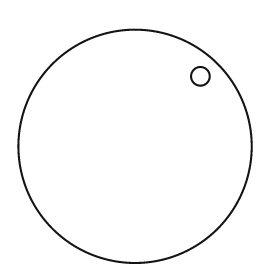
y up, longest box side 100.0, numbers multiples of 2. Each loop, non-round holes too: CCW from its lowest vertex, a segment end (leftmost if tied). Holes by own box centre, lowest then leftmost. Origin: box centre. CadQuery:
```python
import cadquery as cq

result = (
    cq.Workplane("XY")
    .moveTo(0.0, 0.0)
    .circle(50.0)
    .moveTo(28.0, 30.0)
    .circle(4.0)
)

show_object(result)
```